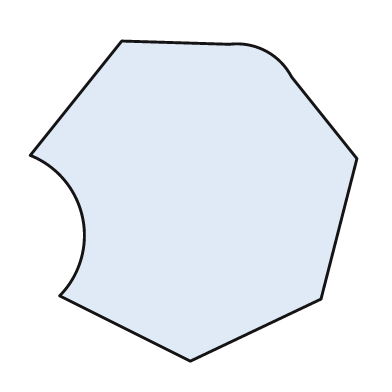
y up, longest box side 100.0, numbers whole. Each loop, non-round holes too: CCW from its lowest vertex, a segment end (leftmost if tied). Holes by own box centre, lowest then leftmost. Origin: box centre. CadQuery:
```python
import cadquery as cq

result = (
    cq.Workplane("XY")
    .moveTo(-1.0, -49.0)
    .lineTo(39.0, -30.0)
    .lineTo(50.0, 13.0)
    .lineTo(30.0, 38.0)
    .threePointArc((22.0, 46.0), (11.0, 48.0))
    .lineTo(-22.0, 49.0)
    .lineTo(-50.0, 14.0)
    .threePointArc((-34.0, -5.0), (-41.0, -29.0))
    .close()
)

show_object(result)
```